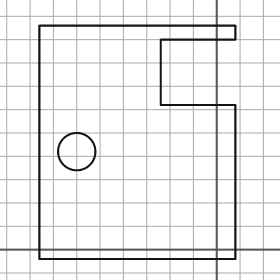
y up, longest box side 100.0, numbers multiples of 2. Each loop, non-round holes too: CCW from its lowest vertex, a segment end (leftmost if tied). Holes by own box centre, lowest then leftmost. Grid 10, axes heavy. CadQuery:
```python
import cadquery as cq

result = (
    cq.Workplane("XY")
    .moveTo(-76.0, -4.0)
    .lineTo(8.0, -4.0)
    .lineTo(8.0, 62.0)
    .lineTo(-24.0, 62.0)
    .lineTo(-24.0, 90.0)
    .lineTo(8.0, 90.0)
    .lineTo(8.0, 96.0)
    .lineTo(-76.0, 96.0)
    .close()
    .moveTo(-60.0, 42.0)
    .circle(8.0)
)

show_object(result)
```